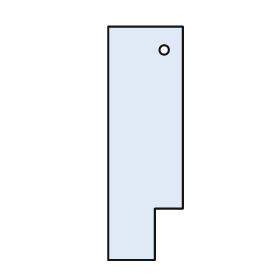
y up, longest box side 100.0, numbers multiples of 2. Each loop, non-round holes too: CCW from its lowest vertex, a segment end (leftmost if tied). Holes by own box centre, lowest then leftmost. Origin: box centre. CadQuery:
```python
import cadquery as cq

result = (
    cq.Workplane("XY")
    .moveTo(-16.0, -50.0)
    .lineTo(4.0, -50.0)
    .lineTo(4.0, -28.0)
    .lineTo(16.0, -28.0)
    .lineTo(16.0, 50.0)
    .lineTo(-16.0, 50.0)
    .close()
    .moveTo(8.0, 40.0)
    .circle(2.0)
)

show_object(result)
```